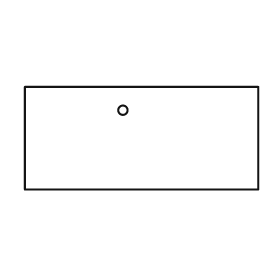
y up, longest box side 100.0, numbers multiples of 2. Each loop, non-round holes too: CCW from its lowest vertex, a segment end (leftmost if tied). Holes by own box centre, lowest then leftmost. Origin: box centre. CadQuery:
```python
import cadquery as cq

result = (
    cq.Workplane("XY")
    .moveTo(-50.0, -22.0)
    .lineTo(50.0, -22.0)
    .lineTo(50.0, 22.0)
    .lineTo(-50.0, 22.0)
    .close()
    .moveTo(-8.0, 12.0)
    .circle(2.0)
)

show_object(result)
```